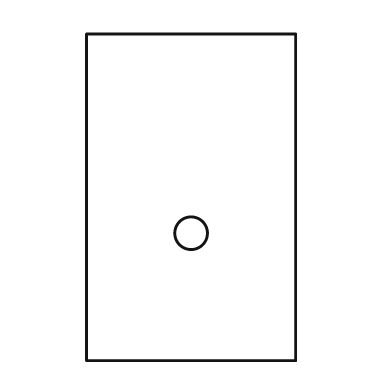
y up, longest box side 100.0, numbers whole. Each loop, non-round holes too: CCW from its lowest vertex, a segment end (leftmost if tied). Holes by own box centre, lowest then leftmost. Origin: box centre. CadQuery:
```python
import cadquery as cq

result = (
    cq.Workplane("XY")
    .moveTo(-32.0, -50.0)
    .lineTo(32.0, -50.0)
    .lineTo(32.0, 50.0)
    .lineTo(-32.0, 50.0)
    .close()
    .moveTo(0.0, -11.0)
    .circle(5.0)
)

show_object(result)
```